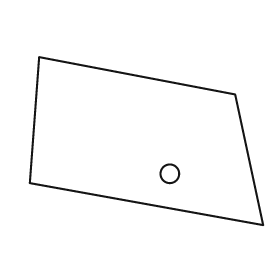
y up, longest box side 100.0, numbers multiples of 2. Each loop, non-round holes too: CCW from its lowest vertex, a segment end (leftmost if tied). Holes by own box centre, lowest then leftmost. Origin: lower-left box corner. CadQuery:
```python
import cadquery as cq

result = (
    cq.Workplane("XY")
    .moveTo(100.0, 0.0)
    .lineTo(88.0, 56.0)
    .lineTo(4.0, 72.0)
    .lineTo(0.0, 18.0)
    .close()
    .moveTo(60.0, 22.0)
    .circle(4.0)
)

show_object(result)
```